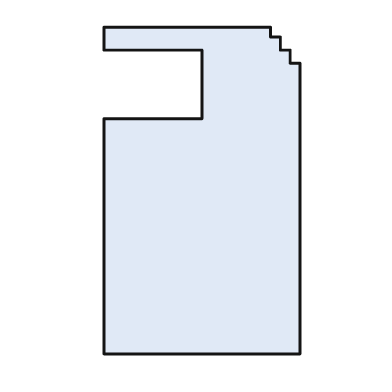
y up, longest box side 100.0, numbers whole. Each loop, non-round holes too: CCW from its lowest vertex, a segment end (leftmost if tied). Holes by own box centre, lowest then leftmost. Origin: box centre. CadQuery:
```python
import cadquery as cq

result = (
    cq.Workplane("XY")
    .moveTo(-30.0, -50.0)
    .lineTo(30.0, -50.0)
    .lineTo(30.0, 39.0)
    .lineTo(27.0, 39.0)
    .lineTo(27.0, 43.0)
    .lineTo(24.0, 43.0)
    .lineTo(24.0, 47.0)
    .lineTo(21.0, 47.0)
    .lineTo(21.0, 50.0)
    .lineTo(-30.0, 50.0)
    .lineTo(-30.0, 43.0)
    .lineTo(0.0, 43.0)
    .lineTo(0.0, 22.0)
    .lineTo(-30.0, 22.0)
    .close()
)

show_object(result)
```